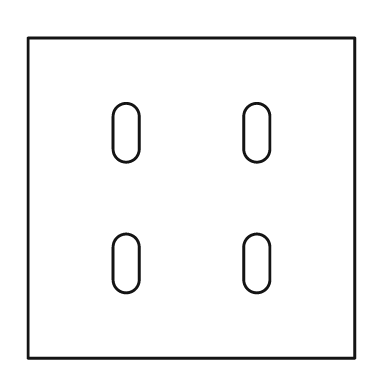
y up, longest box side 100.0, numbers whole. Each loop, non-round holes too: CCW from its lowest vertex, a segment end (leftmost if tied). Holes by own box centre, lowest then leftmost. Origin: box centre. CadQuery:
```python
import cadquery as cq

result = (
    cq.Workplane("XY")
    .moveTo(-50.0, -49.0)
    .lineTo(50.0, -49.0)
    .lineTo(50.0, 49.0)
    .lineTo(-50.0, 49.0)
    .close()
    .moveTo(-24.0, -25.0)
    .threePointArc((-20.0, -29.0), (-16.0, -25.0))
    .lineTo(-16.0, -15.0)
    .threePointArc((-20.0, -11.0), (-24.0, -15.0))
    .close()
    .moveTo(16.0, -25.0)
    .threePointArc((20.0, -29.0), (24.0, -25.0))
    .lineTo(24.0, -15.0)
    .threePointArc((20.0, -11.0), (16.0, -15.0))
    .close()
    .moveTo(-24.0, 15.0)
    .threePointArc((-20.0, 11.0), (-16.0, 15.0))
    .lineTo(-16.0, 25.0)
    .threePointArc((-20.0, 29.0), (-24.0, 25.0))
    .close()
    .moveTo(16.0, 15.0)
    .threePointArc((20.0, 11.0), (24.0, 15.0))
    .lineTo(24.0, 25.0)
    .threePointArc((20.0, 29.0), (16.0, 25.0))
    .close()
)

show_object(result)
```